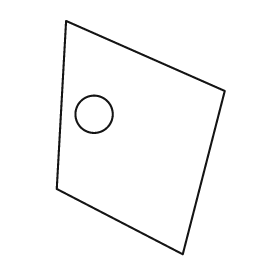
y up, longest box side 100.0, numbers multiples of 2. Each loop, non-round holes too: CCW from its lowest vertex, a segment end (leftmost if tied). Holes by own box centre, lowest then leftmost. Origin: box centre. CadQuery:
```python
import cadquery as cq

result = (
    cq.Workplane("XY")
    .moveTo(18.0, -50.0)
    .lineTo(36.0, 20.0)
    .lineTo(-32.0, 50.0)
    .lineTo(-36.0, -22.0)
    .close()
    .moveTo(-20.0, 10.0)
    .circle(8.0)
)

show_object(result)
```